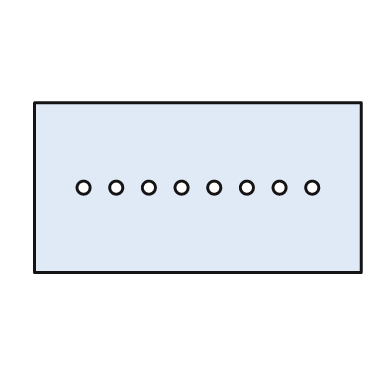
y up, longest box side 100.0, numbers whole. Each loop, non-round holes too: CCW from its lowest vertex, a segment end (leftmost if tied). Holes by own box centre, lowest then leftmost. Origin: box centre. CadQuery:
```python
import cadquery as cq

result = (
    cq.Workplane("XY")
    .moveTo(-50.0, -26.0)
    .lineTo(50.0, -26.0)
    .lineTo(50.0, 26.0)
    .lineTo(-50.0, 26.0)
    .close()
    .moveTo(-35.0, 0.0)
    .circle(2.0)
    .moveTo(-25.0, 0.0)
    .circle(2.0)
    .moveTo(-15.0, 0.0)
    .circle(2.0)
    .moveTo(-5.0, 0.0)
    .circle(2.0)
    .moveTo(5.0, 0.0)
    .circle(2.0)
    .moveTo(15.0, 0.0)
    .circle(2.0)
    .moveTo(25.0, 0.0)
    .circle(2.0)
    .moveTo(35.0, 0.0)
    .circle(2.0)
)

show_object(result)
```